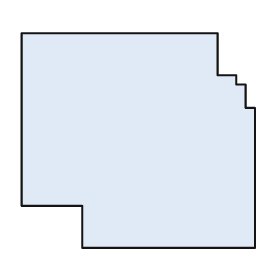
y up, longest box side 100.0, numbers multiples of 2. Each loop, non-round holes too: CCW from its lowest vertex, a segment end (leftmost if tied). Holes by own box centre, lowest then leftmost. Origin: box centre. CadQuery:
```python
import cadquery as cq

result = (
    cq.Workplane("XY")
    .moveTo(-24.0, -46.0)
    .lineTo(50.0, -46.0)
    .lineTo(50.0, 14.0)
    .lineTo(46.0, 14.0)
    .lineTo(46.0, 24.0)
    .lineTo(42.0, 24.0)
    .lineTo(42.0, 28.0)
    .lineTo(34.0, 28.0)
    .lineTo(34.0, 46.0)
    .lineTo(-50.0, 46.0)
    .lineTo(-50.0, -28.0)
    .lineTo(-24.0, -28.0)
    .close()
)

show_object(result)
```